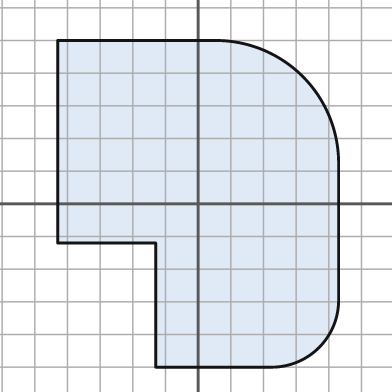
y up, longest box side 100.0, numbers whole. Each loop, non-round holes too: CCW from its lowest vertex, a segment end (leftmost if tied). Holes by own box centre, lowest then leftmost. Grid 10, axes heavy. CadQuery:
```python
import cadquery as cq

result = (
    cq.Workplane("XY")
    .moveTo(-13.0, -50.0)
    .lineTo(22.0, -50.0)
    .threePointArc((37.0, -44.0), (43.0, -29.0))
    .lineTo(43.0, 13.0)
    .threePointArc((32.0, 39.0), (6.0, 50.0))
    .lineTo(-43.0, 50.0)
    .lineTo(-43.0, -12.0)
    .lineTo(-13.0, -12.0)
    .close()
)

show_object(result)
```